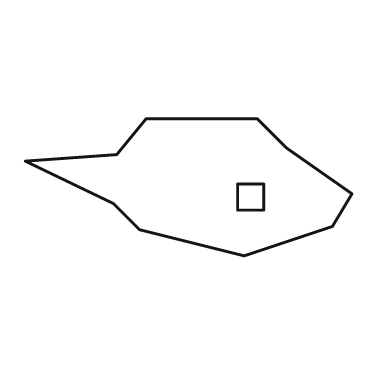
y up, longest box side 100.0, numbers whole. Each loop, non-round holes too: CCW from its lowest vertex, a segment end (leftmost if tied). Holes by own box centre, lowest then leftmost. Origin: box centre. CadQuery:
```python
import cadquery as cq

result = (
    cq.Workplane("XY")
    .moveTo(17.0, -21.0)
    .lineTo(44.0, -12.0)
    .lineTo(50.0, -2.0)
    .lineTo(30.0, 12.0)
    .lineTo(21.0, 21.0)
    .lineTo(-13.0, 21.0)
    .lineTo(-22.0, 10.0)
    .lineTo(-50.0, 8.0)
    .lineTo(-23.0, -5.0)
    .lineTo(-15.0, -13.0)
    .close()
    .moveTo(15.0, -7.0)
    .lineTo(23.0, -7.0)
    .lineTo(23.0, 1.0)
    .lineTo(15.0, 1.0)
    .close()
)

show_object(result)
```